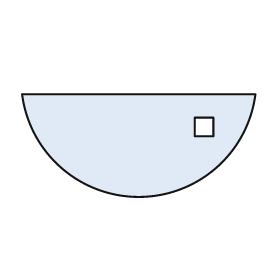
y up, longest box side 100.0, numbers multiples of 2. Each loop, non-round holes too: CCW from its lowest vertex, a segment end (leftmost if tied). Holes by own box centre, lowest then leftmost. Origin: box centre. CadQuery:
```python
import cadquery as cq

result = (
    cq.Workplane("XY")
    .moveTo(-50.0, 22.0)
    .threePointArc((0.0, -22.0), (50.0, 22.0))
    .close()
    .moveTo(24.0, 4.0)
    .lineTo(32.0, 4.0)
    .lineTo(32.0, 12.0)
    .lineTo(24.0, 12.0)
    .close()
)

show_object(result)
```